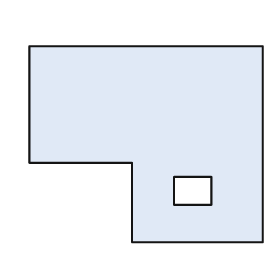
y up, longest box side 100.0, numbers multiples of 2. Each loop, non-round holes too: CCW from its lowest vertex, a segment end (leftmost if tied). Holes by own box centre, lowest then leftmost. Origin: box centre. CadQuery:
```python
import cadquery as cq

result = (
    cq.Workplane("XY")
    .moveTo(-6.0, -42.0)
    .lineTo(50.0, -42.0)
    .lineTo(50.0, 42.0)
    .lineTo(-50.0, 42.0)
    .lineTo(-50.0, -8.0)
    .lineTo(-6.0, -8.0)
    .close()
    .moveTo(12.0, -26.0)
    .lineTo(28.0, -26.0)
    .lineTo(28.0, -14.0)
    .lineTo(12.0, -14.0)
    .close()
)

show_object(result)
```